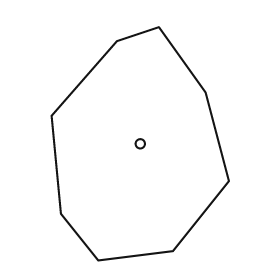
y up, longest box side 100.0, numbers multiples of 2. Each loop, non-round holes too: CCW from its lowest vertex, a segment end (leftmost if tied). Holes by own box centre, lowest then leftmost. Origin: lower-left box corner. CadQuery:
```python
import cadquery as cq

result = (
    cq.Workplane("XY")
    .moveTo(20.0, 0.0)
    .lineTo(52.0, 4.0)
    .lineTo(76.0, 34.0)
    .lineTo(66.0, 72.0)
    .lineTo(46.0, 100.0)
    .lineTo(28.0, 94.0)
    .lineTo(0.0, 62.0)
    .lineTo(4.0, 20.0)
    .close()
    .moveTo(38.0, 50.0)
    .circle(2.0)
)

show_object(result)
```